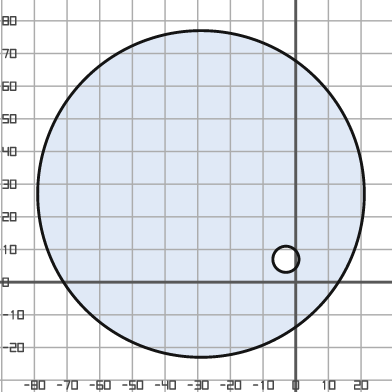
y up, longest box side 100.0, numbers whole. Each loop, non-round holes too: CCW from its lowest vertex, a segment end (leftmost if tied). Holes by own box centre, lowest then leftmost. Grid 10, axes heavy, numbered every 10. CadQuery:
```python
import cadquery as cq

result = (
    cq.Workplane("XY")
    .moveTo(-29.0, 27.0)
    .circle(50.0)
    .moveTo(-3.0, 7.0)
    .circle(4.0)
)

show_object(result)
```